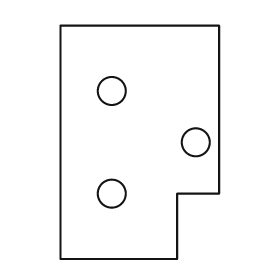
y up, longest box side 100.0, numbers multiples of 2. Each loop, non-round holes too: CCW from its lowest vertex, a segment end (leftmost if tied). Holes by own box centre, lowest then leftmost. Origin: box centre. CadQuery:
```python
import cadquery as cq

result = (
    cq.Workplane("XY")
    .moveTo(-34.0, -50.0)
    .lineTo(16.0, -50.0)
    .lineTo(16.0, -22.0)
    .lineTo(34.0, -22.0)
    .lineTo(34.0, 50.0)
    .lineTo(-34.0, 50.0)
    .close()
    .moveTo(-12.0, -22.0)
    .circle(6.0)
    .moveTo(24.0, 0.0)
    .circle(6.0)
    .moveTo(-12.0, 22.0)
    .circle(6.0)
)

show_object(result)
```